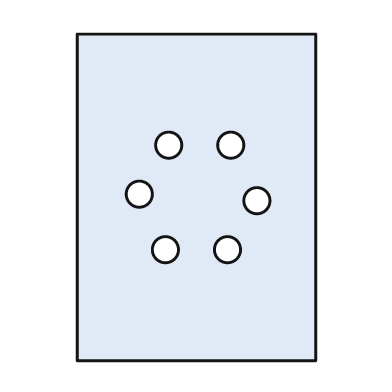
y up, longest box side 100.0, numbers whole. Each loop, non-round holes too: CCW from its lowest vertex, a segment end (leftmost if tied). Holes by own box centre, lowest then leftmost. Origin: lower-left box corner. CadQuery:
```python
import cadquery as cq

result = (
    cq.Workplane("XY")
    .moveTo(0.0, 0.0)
    .lineTo(73.0, 0.0)
    .lineTo(73.0, 100.0)
    .lineTo(0.0, 100.0)
    .close()
    .moveTo(27.0, 34.0)
    .circle(4.0)
    .moveTo(46.0, 34.0)
    .circle(4.0)
    .moveTo(55.0, 49.0)
    .circle(4.0)
    .moveTo(19.0, 51.0)
    .circle(4.0)
    .moveTo(28.0, 66.0)
    .circle(4.0)
    .moveTo(47.0, 66.0)
    .circle(4.0)
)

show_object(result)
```